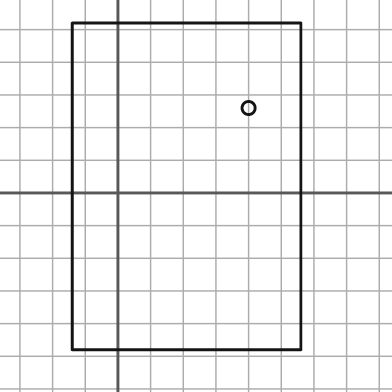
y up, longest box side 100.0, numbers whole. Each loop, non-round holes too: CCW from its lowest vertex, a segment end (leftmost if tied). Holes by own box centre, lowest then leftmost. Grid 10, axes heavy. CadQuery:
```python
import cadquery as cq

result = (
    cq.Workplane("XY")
    .moveTo(-14.0, -48.0)
    .lineTo(56.0, -48.0)
    .lineTo(56.0, 52.0)
    .lineTo(-14.0, 52.0)
    .close()
    .moveTo(40.0, 26.0)
    .circle(2.0)
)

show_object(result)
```